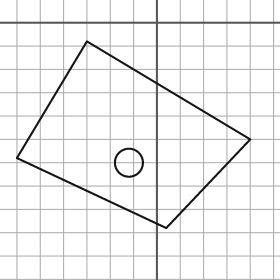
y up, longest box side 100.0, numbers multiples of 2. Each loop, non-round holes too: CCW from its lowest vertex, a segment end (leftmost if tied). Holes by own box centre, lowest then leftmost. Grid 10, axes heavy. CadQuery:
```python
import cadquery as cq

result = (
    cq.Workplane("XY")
    .moveTo(4.0, -88.0)
    .lineTo(40.0, -50.0)
    .lineTo(-30.0, -8.0)
    .lineTo(-60.0, -58.0)
    .close()
    .moveTo(-12.0, -60.0)
    .circle(6.0)
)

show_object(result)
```